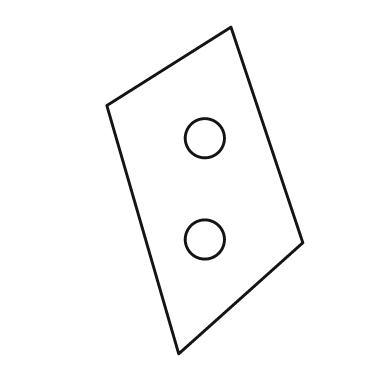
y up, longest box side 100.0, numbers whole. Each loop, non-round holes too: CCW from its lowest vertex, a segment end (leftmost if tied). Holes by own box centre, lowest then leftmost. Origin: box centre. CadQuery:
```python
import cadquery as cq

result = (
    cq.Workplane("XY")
    .moveTo(-8.0, -50.0)
    .lineTo(30.0, -16.0)
    .lineTo(8.0, 50.0)
    .lineTo(-30.0, 26.0)
    .close()
    .moveTo(0.0, -15.0)
    .circle(6.0)
    .moveTo(0.0, 16.0)
    .circle(6.0)
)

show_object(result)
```